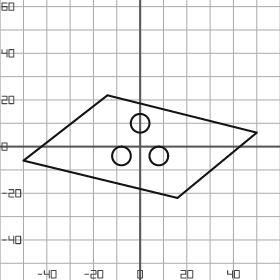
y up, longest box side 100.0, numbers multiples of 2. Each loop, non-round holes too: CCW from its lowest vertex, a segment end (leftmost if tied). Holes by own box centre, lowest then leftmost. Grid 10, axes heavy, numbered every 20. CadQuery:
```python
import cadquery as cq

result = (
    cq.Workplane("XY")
    .moveTo(16.0, -22.0)
    .lineTo(50.0, 6.0)
    .lineTo(-14.0, 22.0)
    .lineTo(-50.0, -6.0)
    .close()
    .moveTo(-8.0, -4.0)
    .circle(4.0)
    .moveTo(8.0, -4.0)
    .circle(4.0)
    .moveTo(0.0, 10.0)
    .circle(4.0)
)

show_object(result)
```